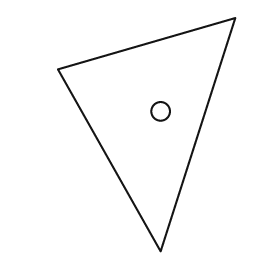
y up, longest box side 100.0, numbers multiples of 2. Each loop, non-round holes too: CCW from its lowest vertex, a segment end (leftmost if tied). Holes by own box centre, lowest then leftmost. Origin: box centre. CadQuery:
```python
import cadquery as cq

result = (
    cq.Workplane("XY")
    .moveTo(6.0, -50.0)
    .lineTo(38.0, 50.0)
    .lineTo(-38.0, 28.0)
    .close()
    .moveTo(6.0, 10.0)
    .circle(4.0)
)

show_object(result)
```